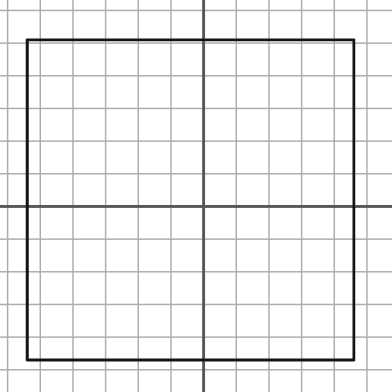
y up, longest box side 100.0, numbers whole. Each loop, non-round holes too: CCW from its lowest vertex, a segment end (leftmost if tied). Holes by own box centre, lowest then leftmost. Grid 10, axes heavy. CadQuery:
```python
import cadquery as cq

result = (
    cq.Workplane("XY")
    .moveTo(-54.0, -47.0)
    .lineTo(46.0, -47.0)
    .lineTo(46.0, 51.0)
    .lineTo(-54.0, 51.0)
    .close()
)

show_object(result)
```